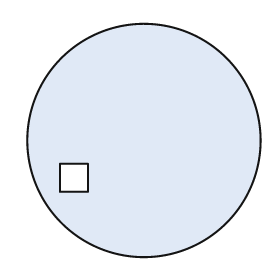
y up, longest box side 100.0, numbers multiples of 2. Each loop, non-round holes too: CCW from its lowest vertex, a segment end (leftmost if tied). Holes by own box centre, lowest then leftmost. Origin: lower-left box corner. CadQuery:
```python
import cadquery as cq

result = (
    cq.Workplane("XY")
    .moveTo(50.0, 50.0)
    .circle(50.0)
    .moveTo(14.0, 28.0)
    .lineTo(26.0, 28.0)
    .lineTo(26.0, 40.0)
    .lineTo(14.0, 40.0)
    .close()
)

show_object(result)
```